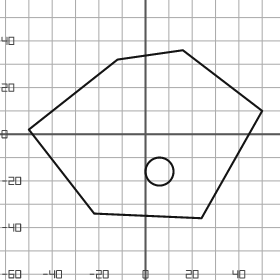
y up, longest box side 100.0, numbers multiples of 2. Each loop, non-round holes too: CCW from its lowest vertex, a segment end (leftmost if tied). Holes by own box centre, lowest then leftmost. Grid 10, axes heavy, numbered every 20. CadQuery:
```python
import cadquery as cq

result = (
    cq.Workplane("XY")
    .moveTo(24.0, -36.0)
    .lineTo(50.0, 10.0)
    .lineTo(16.0, 36.0)
    .lineTo(-12.0, 32.0)
    .lineTo(-50.0, 2.0)
    .lineTo(-22.0, -34.0)
    .close()
    .moveTo(6.0, -16.0)
    .circle(6.0)
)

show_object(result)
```